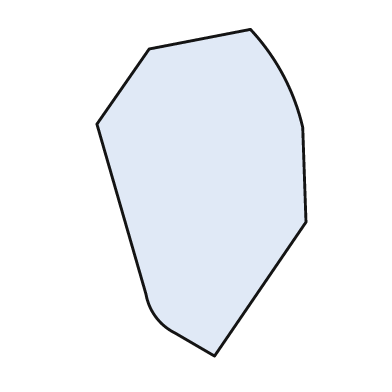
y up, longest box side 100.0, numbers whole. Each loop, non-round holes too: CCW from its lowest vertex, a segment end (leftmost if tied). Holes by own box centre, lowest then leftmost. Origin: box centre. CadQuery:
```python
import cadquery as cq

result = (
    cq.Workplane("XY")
    .moveTo(4.0, -50.0)
    .lineTo(32.0, -9.0)
    .lineTo(31.0, 20.0)
    .threePointArc((25.0, 36.0), (15.0, 50.0))
    .lineTo(-16.0, 44.0)
    .lineTo(-32.0, 21.0)
    .lineTo(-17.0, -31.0)
    .threePointArc((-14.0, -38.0), (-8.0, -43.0))
    .close()
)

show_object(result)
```